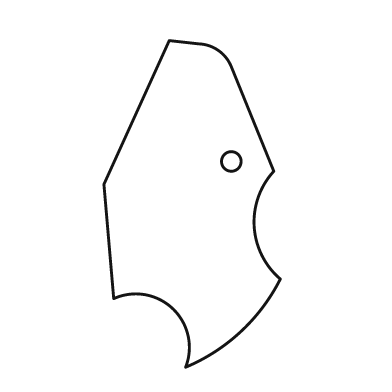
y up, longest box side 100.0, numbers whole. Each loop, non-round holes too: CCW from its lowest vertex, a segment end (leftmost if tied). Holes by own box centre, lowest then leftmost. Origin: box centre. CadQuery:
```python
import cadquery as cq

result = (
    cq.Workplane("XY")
    .moveTo(-2.0, -50.0)
    .threePointArc((15.0, -39.0), (27.0, -23.0))
    .threePointArc((19.0, -7.0), (25.0, 10.0))
    .lineTo(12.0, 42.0)
    .threePointArc((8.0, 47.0), (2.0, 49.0))
    .lineTo(-7.0, 50.0)
    .lineTo(-27.0, 6.0)
    .lineTo(-24.0, -29.0)
    .threePointArc((-6.0, -32.0), (-2.0, -50.0))
    .close()
    .moveTo(12.0, 13.0)
    .circle(3.0)
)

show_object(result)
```